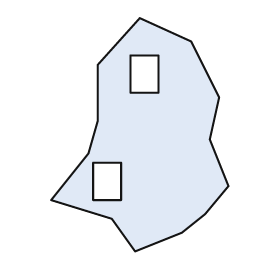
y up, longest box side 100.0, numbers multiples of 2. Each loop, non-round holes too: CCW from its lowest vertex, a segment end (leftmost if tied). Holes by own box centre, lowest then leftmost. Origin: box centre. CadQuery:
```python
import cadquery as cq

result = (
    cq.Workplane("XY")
    .moveTo(-2.0, -50.0)
    .lineTo(18.0, -42.0)
    .lineTo(28.0, -34.0)
    .lineTo(38.0, -22.0)
    .lineTo(30.0, -2.0)
    .lineTo(34.0, 16.0)
    .lineTo(22.0, 40.0)
    .lineTo(0.0, 50.0)
    .lineTo(-18.0, 30.0)
    .lineTo(-18.0, 6.0)
    .lineTo(-22.0, -8.0)
    .lineTo(-38.0, -28.0)
    .lineTo(-12.0, -36.0)
    .close()
    .moveTo(-20.0, -28.0)
    .lineTo(-8.0, -28.0)
    .lineTo(-8.0, -12.0)
    .lineTo(-20.0, -12.0)
    .close()
    .moveTo(-4.0, 18.0)
    .lineTo(8.0, 18.0)
    .lineTo(8.0, 34.0)
    .lineTo(-4.0, 34.0)
    .close()
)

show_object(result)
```